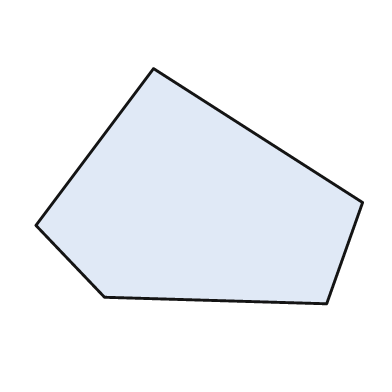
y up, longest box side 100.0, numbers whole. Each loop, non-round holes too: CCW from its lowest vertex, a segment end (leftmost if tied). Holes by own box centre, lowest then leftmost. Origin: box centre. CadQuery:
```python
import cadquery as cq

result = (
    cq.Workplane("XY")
    .moveTo(39.0, -36.0)
    .lineTo(50.0, -5.0)
    .lineTo(-14.0, 36.0)
    .lineTo(-50.0, -12.0)
    .lineTo(-29.0, -34.0)
    .close()
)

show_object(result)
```